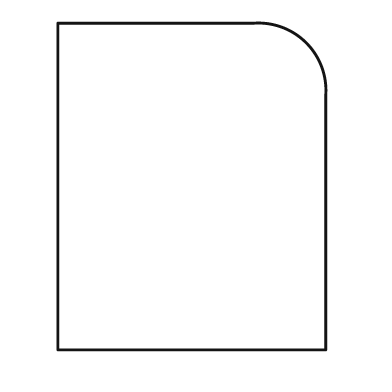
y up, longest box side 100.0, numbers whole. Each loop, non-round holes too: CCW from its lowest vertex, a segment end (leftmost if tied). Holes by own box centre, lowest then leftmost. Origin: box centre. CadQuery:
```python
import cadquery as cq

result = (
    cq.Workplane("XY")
    .moveTo(-41.0, -50.0)
    .lineTo(41.0, -50.0)
    .lineTo(41.0, 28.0)
    .threePointArc((35.0, 44.0), (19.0, 50.0))
    .lineTo(-41.0, 50.0)
    .close()
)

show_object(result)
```